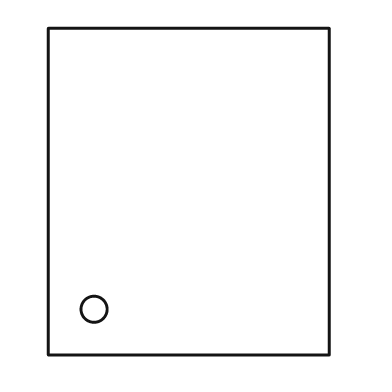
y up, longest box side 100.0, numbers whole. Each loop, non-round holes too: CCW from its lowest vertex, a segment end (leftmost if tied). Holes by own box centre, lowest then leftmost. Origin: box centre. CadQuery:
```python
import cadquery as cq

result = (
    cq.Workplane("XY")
    .moveTo(-43.0, -50.0)
    .lineTo(43.0, -50.0)
    .lineTo(43.0, 50.0)
    .lineTo(-43.0, 50.0)
    .close()
    .moveTo(-29.0, -36.0)
    .circle(4.0)
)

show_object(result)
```